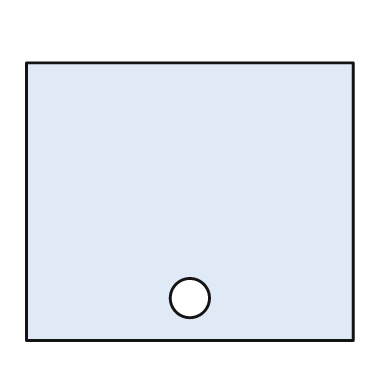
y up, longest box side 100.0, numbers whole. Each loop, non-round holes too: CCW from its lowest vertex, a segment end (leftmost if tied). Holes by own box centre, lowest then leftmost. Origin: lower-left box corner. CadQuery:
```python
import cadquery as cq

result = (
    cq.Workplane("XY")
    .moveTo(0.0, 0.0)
    .lineTo(100.0, 0.0)
    .lineTo(100.0, 85.0)
    .lineTo(0.0, 85.0)
    .close()
    .moveTo(50.0, 13.0)
    .circle(6.0)
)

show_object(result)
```